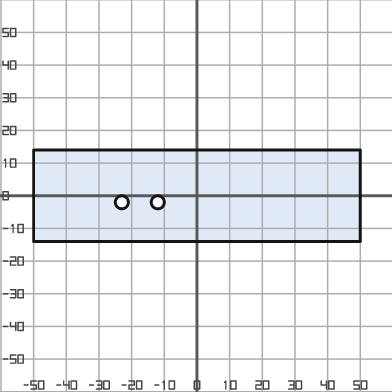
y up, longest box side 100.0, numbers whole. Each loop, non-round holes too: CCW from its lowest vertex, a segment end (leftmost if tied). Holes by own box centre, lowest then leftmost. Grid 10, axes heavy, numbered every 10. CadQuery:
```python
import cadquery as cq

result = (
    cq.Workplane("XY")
    .moveTo(-50.0, -14.0)
    .lineTo(50.0, -14.0)
    .lineTo(50.0, 14.0)
    .lineTo(-50.0, 14.0)
    .close()
    .moveTo(-23.0, -2.0)
    .circle(2.0)
    .moveTo(-12.0, -2.0)
    .circle(2.0)
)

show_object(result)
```